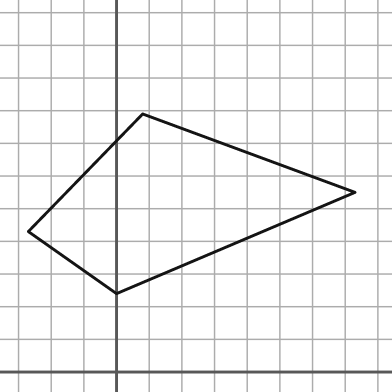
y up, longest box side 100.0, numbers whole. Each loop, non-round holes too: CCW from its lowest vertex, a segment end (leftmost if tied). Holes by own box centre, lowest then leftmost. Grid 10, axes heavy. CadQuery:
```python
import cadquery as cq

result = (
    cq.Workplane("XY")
    .moveTo(0.0, 24.0)
    .lineTo(73.0, 55.0)
    .lineTo(8.0, 79.0)
    .lineTo(-27.0, 43.0)
    .close()
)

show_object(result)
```